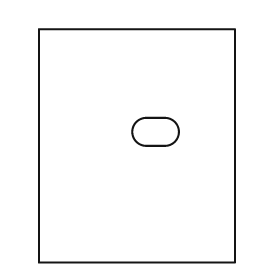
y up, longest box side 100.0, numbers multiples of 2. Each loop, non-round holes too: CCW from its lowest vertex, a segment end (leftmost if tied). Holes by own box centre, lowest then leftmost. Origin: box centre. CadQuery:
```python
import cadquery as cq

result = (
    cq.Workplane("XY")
    .moveTo(-42.0, -50.0)
    .lineTo(42.0, -50.0)
    .lineTo(42.0, 50.0)
    .lineTo(-42.0, 50.0)
    .close()
    .moveTo(4.0, 0.0)
    .lineTo(12.0, 0.0)
    .threePointArc((18.0, 6.0), (12.0, 12.0))
    .lineTo(4.0, 12.0)
    .threePointArc((-2.0, 6.0), (4.0, 0.0))
    .close()
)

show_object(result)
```